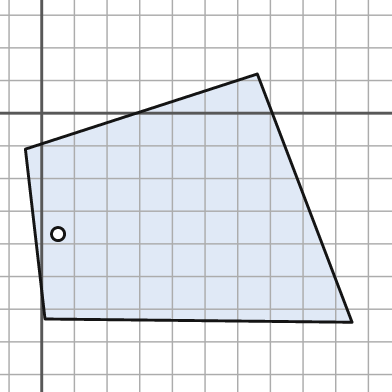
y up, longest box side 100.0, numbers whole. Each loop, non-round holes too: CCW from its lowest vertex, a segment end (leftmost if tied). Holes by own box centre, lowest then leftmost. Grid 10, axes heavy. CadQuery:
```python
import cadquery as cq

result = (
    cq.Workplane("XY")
    .moveTo(95.0, -64.0)
    .lineTo(66.0, 12.0)
    .lineTo(-5.0, -11.0)
    .lineTo(1.0, -63.0)
    .close()
    .moveTo(5.0, -37.0)
    .circle(2.0)
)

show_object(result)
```